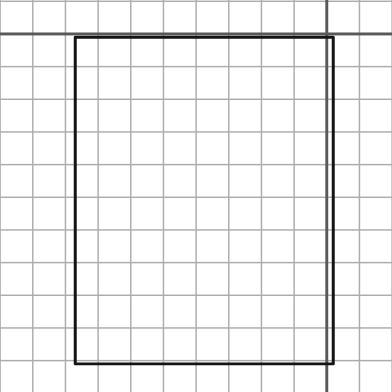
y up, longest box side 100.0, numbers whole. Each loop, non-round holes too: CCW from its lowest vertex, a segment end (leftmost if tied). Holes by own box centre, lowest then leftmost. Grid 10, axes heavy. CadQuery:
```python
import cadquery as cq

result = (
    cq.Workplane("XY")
    .moveTo(-77.0, -101.0)
    .lineTo(2.0, -101.0)
    .lineTo(2.0, -1.0)
    .lineTo(-77.0, -1.0)
    .close()
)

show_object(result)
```